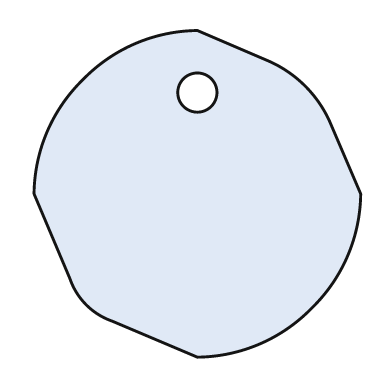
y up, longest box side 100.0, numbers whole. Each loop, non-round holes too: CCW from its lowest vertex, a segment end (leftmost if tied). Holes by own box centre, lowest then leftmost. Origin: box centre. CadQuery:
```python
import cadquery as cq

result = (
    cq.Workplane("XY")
    .moveTo(0.0, -50.0)
    .threePointArc((19.0, -46.0), (35.0, -35.0))
    .threePointArc((46.0, -19.0), (50.0, 0.0))
    .lineTo(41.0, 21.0)
    .threePointArc((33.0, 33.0), (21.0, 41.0))
    .lineTo(0.0, 50.0)
    .threePointArc((-19.0, 46.0), (-35.0, 35.0))
    .threePointArc((-46.0, 19.0), (-50.0, 0.0))
    .lineTo(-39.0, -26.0)
    .threePointArc((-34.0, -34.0), (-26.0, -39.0))
    .close()
    .moveTo(0.0, 31.0)
    .circle(6.0)
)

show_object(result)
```